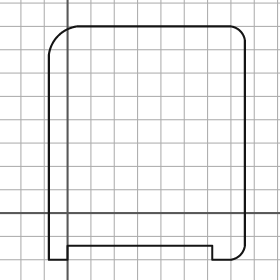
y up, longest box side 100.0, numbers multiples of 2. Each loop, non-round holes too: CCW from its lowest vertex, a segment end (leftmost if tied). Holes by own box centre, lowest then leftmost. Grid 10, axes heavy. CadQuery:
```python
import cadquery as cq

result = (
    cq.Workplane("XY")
    .moveTo(-8.0, -20.0)
    .lineTo(0.0, -20.0)
    .lineTo(0.0, -14.0)
    .lineTo(62.0, -14.0)
    .lineTo(62.0, -20.0)
    .lineTo(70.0, -20.0)
    .threePointArc((74.0, -18.0), (76.0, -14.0))
    .lineTo(76.0, 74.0)
    .threePointArc((74.0, 78.0), (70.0, 80.0))
    .lineTo(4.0, 80.0)
    .threePointArc((-4.0, 76.0), (-8.0, 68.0))
    .close()
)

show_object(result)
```